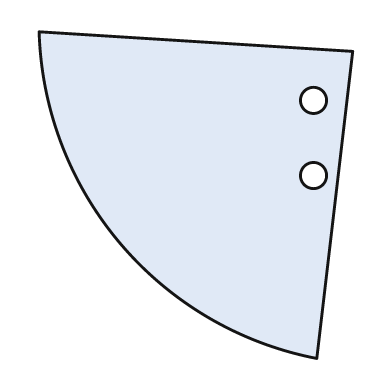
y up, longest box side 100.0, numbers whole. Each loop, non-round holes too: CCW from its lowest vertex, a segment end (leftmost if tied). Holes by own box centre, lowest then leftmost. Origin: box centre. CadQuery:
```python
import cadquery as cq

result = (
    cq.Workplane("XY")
    .moveTo(37.0, -50.0)
    .lineTo(48.0, 44.0)
    .lineTo(-48.0, 50.0)
    .threePointArc((-23.0, -15.0), (37.0, -50.0))
    .close()
    .moveTo(36.0, 6.0)
    .circle(4.0)
    .moveTo(36.0, 29.0)
    .circle(4.0)
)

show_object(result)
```